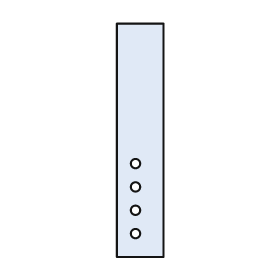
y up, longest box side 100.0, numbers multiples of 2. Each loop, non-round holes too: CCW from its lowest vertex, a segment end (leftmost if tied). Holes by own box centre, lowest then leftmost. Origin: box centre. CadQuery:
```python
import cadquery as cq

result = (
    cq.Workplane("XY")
    .moveTo(-10.0, -50.0)
    .lineTo(10.0, -50.0)
    .lineTo(10.0, 50.0)
    .lineTo(-10.0, 50.0)
    .close()
    .moveTo(-2.0, -40.0)
    .circle(2.0)
    .moveTo(-2.0, -30.0)
    .circle(2.0)
    .moveTo(-2.0, -20.0)
    .circle(2.0)
    .moveTo(-2.0, -10.0)
    .circle(2.0)
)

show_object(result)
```